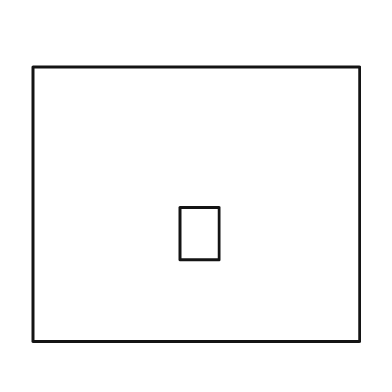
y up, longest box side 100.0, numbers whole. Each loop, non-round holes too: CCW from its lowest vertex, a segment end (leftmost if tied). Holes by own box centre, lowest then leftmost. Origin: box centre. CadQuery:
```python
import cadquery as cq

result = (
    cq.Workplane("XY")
    .moveTo(-50.0, -42.0)
    .lineTo(50.0, -42.0)
    .lineTo(50.0, 42.0)
    .lineTo(-50.0, 42.0)
    .close()
    .moveTo(-5.0, -17.0)
    .lineTo(7.0, -17.0)
    .lineTo(7.0, -1.0)
    .lineTo(-5.0, -1.0)
    .close()
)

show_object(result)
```